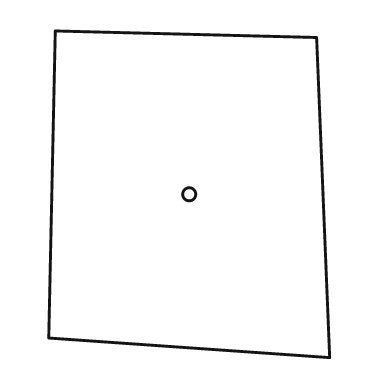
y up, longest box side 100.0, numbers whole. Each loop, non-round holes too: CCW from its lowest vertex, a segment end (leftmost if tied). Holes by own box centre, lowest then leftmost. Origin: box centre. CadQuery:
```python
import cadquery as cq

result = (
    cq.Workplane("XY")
    .moveTo(43.0, -50.0)
    .lineTo(39.0, 48.0)
    .lineTo(-41.0, 50.0)
    .lineTo(-43.0, -44.0)
    .close()
    .moveTo(0.0, 0.0)
    .circle(2.0)
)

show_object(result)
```